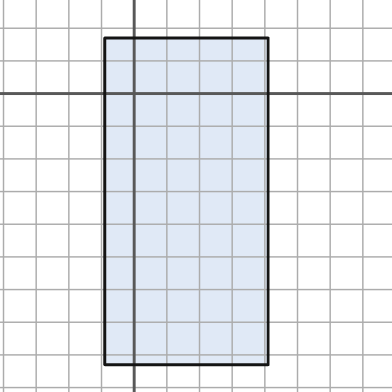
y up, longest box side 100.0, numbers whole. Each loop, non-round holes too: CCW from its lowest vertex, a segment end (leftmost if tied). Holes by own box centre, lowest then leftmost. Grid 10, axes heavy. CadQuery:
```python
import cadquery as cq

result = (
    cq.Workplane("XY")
    .moveTo(-9.0, -83.0)
    .lineTo(41.0, -83.0)
    .lineTo(41.0, 17.0)
    .lineTo(-9.0, 17.0)
    .close()
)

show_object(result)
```